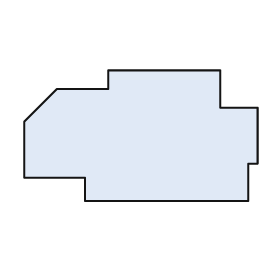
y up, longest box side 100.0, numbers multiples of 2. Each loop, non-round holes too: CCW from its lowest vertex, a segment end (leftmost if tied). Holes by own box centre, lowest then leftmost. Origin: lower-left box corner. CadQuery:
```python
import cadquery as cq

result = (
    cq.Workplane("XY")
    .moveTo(26.0, 0.0)
    .lineTo(96.0, 0.0)
    .lineTo(96.0, 16.0)
    .lineTo(100.0, 16.0)
    .lineTo(100.0, 40.0)
    .lineTo(84.0, 40.0)
    .lineTo(84.0, 56.0)
    .lineTo(36.0, 56.0)
    .lineTo(36.0, 48.0)
    .lineTo(14.0, 48.0)
    .lineTo(0.0, 34.0)
    .lineTo(0.0, 10.0)
    .lineTo(26.0, 10.0)
    .close()
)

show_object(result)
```